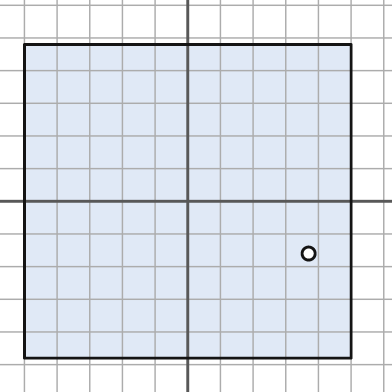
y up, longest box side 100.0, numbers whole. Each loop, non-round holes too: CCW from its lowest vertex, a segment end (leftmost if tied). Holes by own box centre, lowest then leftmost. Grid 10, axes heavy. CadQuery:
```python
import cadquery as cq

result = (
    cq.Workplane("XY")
    .moveTo(-50.0, -48.0)
    .lineTo(50.0, -48.0)
    .lineTo(50.0, 48.0)
    .lineTo(-50.0, 48.0)
    .close()
    .moveTo(37.0, -16.0)
    .circle(2.0)
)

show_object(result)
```